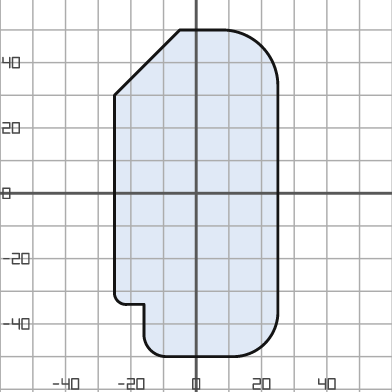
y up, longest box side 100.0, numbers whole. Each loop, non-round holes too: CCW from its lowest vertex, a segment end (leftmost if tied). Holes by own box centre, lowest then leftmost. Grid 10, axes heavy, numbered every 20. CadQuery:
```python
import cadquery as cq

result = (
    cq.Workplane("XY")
    .moveTo(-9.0, -50.0)
    .lineTo(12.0, -50.0)
    .threePointArc((21.0, -46.0), (25.0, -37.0))
    .lineTo(25.0, 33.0)
    .threePointArc((20.0, 45.0), (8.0, 50.0))
    .lineTo(-5.0, 50.0)
    .lineTo(-25.0, 30.0)
    .lineTo(-25.0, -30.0)
    .threePointArc((-24.0, -33.0), (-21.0, -34.0))
    .lineTo(-16.0, -34.0)
    .lineTo(-16.0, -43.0)
    .threePointArc((-14.0, -48.0), (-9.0, -50.0))
    .close()
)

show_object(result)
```